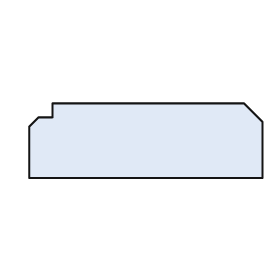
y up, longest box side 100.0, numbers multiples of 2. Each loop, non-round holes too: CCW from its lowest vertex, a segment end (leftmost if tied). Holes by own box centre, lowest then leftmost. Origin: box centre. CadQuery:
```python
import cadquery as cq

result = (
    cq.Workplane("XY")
    .moveTo(-50.0, -16.0)
    .lineTo(50.0, -16.0)
    .lineTo(50.0, 8.0)
    .lineTo(42.0, 16.0)
    .lineTo(-40.0, 16.0)
    .lineTo(-40.0, 10.0)
    .lineTo(-46.0, 10.0)
    .lineTo(-50.0, 6.0)
    .close()
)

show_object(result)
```